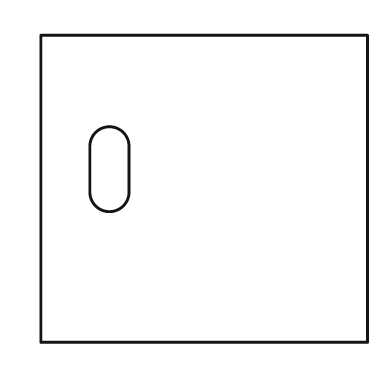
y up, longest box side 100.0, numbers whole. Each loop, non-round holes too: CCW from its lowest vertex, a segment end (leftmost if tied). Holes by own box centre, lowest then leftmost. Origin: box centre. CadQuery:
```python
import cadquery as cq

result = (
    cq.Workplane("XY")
    .moveTo(-50.0, -47.0)
    .lineTo(50.0, -47.0)
    .lineTo(50.0, 47.0)
    .lineTo(-50.0, 47.0)
    .close()
    .moveTo(-35.0, -1.0)
    .threePointArc((-29.0, -7.0), (-23.0, -1.0))
    .lineTo(-23.0, 13.0)
    .threePointArc((-29.0, 19.0), (-35.0, 13.0))
    .close()
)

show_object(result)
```